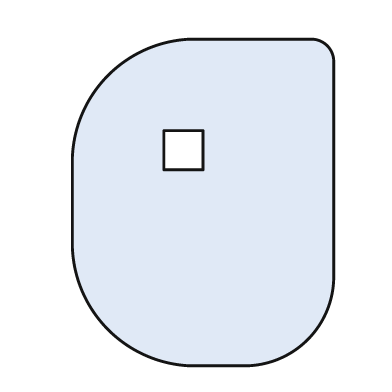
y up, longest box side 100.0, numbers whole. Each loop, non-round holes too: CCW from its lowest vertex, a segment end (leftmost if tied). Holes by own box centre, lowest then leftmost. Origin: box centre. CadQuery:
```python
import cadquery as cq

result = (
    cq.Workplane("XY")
    .moveTo(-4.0, -50.0)
    .lineTo(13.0, -50.0)
    .threePointArc((32.0, -42.0), (40.0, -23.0))
    .lineTo(40.0, 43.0)
    .threePointArc((38.0, 48.0), (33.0, 50.0))
    .lineTo(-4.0, 50.0)
    .threePointArc((-29.0, 39.0), (-40.0, 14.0))
    .lineTo(-40.0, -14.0)
    .threePointArc((-29.0, -39.0), (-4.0, -50.0))
    .close()
    .moveTo(-12.0, 10.0)
    .lineTo(0.0, 10.0)
    .lineTo(0.0, 22.0)
    .lineTo(-12.0, 22.0)
    .close()
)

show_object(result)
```